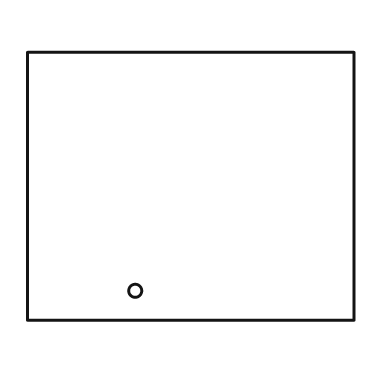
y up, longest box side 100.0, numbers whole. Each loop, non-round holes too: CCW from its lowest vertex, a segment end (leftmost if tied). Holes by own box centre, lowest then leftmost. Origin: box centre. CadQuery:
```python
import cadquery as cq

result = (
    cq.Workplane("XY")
    .moveTo(-50.0, -41.0)
    .lineTo(50.0, -41.0)
    .lineTo(50.0, 41.0)
    .lineTo(-50.0, 41.0)
    .close()
    .moveTo(-17.0, -32.0)
    .circle(2.0)
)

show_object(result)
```